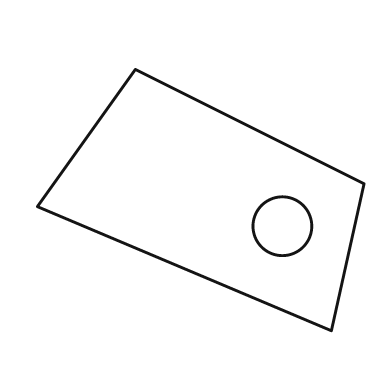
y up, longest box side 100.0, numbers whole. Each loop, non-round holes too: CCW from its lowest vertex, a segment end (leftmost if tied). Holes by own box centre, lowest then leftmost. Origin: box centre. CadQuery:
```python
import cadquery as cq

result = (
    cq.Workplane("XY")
    .moveTo(40.0, -40.0)
    .lineTo(50.0, 5.0)
    .lineTo(-20.0, 40.0)
    .lineTo(-50.0, -2.0)
    .close()
    .moveTo(25.0, -8.0)
    .circle(9.0)
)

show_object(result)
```